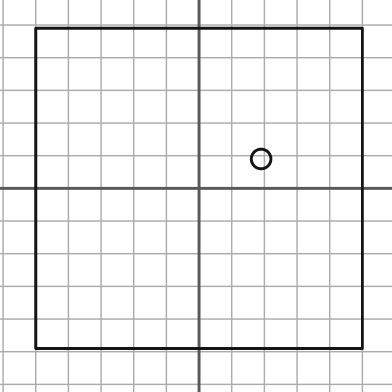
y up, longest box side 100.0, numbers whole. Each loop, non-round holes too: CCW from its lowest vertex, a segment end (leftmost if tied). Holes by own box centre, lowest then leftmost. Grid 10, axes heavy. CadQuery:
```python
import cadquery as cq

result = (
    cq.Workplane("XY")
    .moveTo(-50.0, -49.0)
    .lineTo(50.0, -49.0)
    .lineTo(50.0, 49.0)
    .lineTo(-50.0, 49.0)
    .close()
    .moveTo(19.0, 9.0)
    .circle(3.0)
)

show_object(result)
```